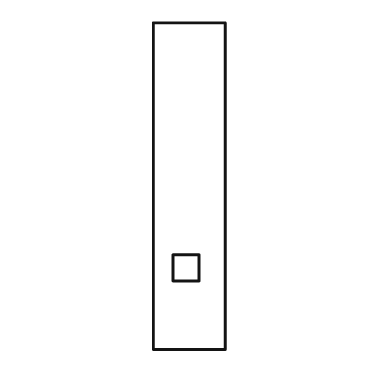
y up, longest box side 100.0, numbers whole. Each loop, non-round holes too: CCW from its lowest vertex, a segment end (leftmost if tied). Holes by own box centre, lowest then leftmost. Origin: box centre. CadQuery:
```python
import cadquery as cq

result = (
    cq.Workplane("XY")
    .moveTo(-11.0, -50.0)
    .lineTo(11.0, -50.0)
    .lineTo(11.0, 50.0)
    .lineTo(-11.0, 50.0)
    .close()
    .moveTo(-5.0, -29.0)
    .lineTo(3.0, -29.0)
    .lineTo(3.0, -21.0)
    .lineTo(-5.0, -21.0)
    .close()
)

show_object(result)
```